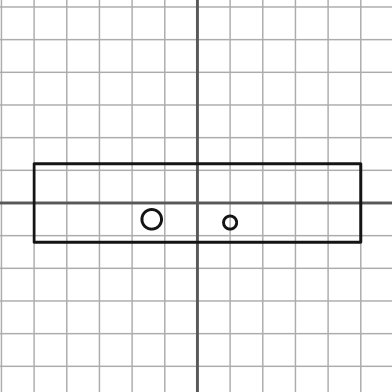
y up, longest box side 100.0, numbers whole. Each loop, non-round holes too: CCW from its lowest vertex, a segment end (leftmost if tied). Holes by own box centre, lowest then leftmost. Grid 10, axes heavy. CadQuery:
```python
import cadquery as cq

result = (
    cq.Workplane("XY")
    .moveTo(-50.0, -12.0)
    .lineTo(50.0, -12.0)
    .lineTo(50.0, 12.0)
    .lineTo(-50.0, 12.0)
    .close()
    .moveTo(10.0, -6.0)
    .circle(2.0)
    .moveTo(-14.0, -5.0)
    .circle(3.0)
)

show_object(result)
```